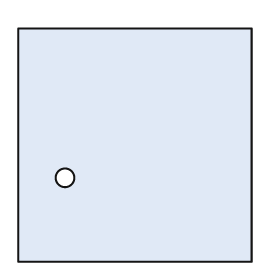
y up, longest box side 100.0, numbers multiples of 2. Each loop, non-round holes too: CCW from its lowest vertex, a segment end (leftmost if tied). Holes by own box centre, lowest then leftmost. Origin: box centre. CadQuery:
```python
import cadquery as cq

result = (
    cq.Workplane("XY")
    .moveTo(-50.0, -50.0)
    .lineTo(50.0, -50.0)
    .lineTo(50.0, 50.0)
    .lineTo(-50.0, 50.0)
    .close()
    .moveTo(-30.0, -14.0)
    .circle(4.0)
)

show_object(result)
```